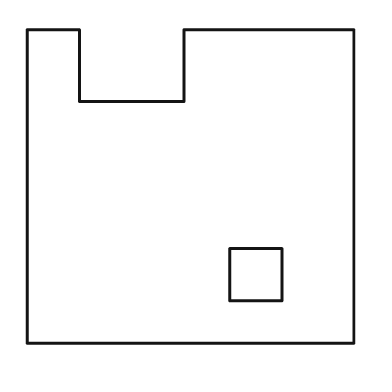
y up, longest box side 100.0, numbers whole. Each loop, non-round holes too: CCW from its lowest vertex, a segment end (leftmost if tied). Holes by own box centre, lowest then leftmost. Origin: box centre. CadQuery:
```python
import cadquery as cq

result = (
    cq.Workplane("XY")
    .moveTo(-50.0, -48.0)
    .lineTo(50.0, -48.0)
    .lineTo(50.0, 48.0)
    .lineTo(-2.0, 48.0)
    .lineTo(-2.0, 26.0)
    .lineTo(-34.0, 26.0)
    .lineTo(-34.0, 48.0)
    .lineTo(-50.0, 48.0)
    .close()
    .moveTo(12.0, -35.0)
    .lineTo(28.0, -35.0)
    .lineTo(28.0, -19.0)
    .lineTo(12.0, -19.0)
    .close()
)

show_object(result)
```